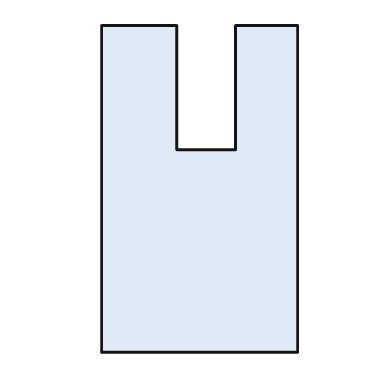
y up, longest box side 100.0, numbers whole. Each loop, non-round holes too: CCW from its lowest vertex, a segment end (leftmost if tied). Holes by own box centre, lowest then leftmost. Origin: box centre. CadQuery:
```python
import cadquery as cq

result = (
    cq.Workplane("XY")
    .moveTo(-30.0, -50.0)
    .lineTo(30.0, -50.0)
    .lineTo(30.0, 50.0)
    .lineTo(11.0, 50.0)
    .lineTo(11.0, 12.0)
    .lineTo(-7.0, 12.0)
    .lineTo(-7.0, 50.0)
    .lineTo(-30.0, 50.0)
    .close()
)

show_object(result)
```